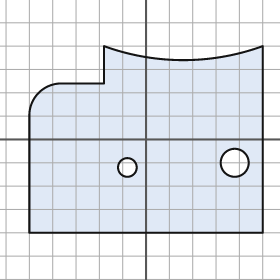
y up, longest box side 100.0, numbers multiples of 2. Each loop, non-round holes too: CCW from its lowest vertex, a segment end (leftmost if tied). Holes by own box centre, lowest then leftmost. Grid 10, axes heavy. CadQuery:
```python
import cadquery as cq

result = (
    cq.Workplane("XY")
    .moveTo(-50.0, -40.0)
    .lineTo(50.0, -40.0)
    .lineTo(50.0, 40.0)
    .threePointArc((16.0, 34.0), (-18.0, 40.0))
    .lineTo(-18.0, 24.0)
    .lineTo(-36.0, 24.0)
    .threePointArc((-46.0, 20.0), (-50.0, 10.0))
    .close()
    .moveTo(-8.0, -12.0)
    .circle(4.0)
    .moveTo(38.0, -10.0)
    .circle(6.0)
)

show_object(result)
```